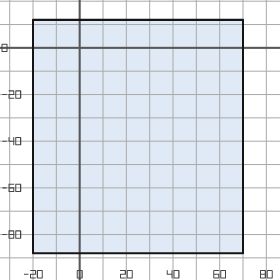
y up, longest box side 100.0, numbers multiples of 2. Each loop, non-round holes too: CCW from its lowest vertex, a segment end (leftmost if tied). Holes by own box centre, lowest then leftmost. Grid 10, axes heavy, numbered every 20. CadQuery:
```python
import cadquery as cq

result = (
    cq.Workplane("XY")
    .moveTo(-20.0, -88.0)
    .lineTo(70.0, -88.0)
    .lineTo(70.0, 12.0)
    .lineTo(-20.0, 12.0)
    .close()
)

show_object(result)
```